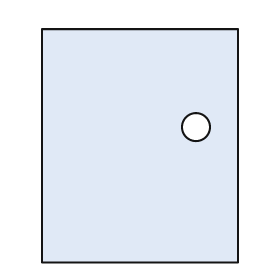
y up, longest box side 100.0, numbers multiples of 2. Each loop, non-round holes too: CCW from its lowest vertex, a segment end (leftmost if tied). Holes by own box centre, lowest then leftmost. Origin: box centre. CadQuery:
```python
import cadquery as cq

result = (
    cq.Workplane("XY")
    .moveTo(-42.0, -50.0)
    .lineTo(42.0, -50.0)
    .lineTo(42.0, 50.0)
    .lineTo(-42.0, 50.0)
    .close()
    .moveTo(24.0, 8.0)
    .circle(6.0)
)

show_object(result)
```